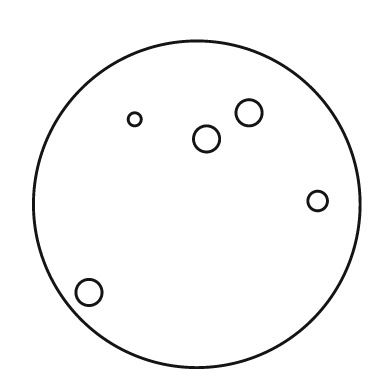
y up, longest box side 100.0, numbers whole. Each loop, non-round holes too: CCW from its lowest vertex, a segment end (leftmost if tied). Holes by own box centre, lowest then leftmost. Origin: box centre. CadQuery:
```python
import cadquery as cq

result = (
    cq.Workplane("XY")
    .moveTo(0.0, 0.0)
    .circle(50.0)
    .moveTo(-33.0, -27.0)
    .circle(4.0)
    .moveTo(37.0, 1.0)
    .circle(3.0)
    .moveTo(3.0, 20.0)
    .circle(4.0)
    .moveTo(-19.0, 26.0)
    .circle(2.0)
    .moveTo(16.0, 28.0)
    .circle(4.0)
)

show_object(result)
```